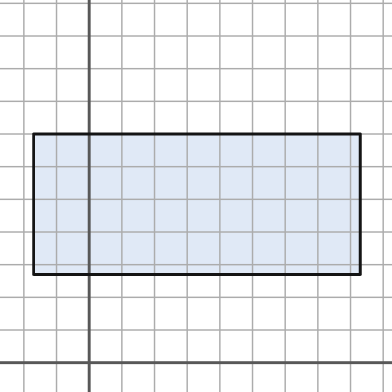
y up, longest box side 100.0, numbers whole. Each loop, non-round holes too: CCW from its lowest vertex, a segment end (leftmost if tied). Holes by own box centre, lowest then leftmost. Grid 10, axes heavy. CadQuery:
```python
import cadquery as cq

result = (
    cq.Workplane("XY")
    .moveTo(-17.0, 27.0)
    .lineTo(83.0, 27.0)
    .lineTo(83.0, 70.0)
    .lineTo(-17.0, 70.0)
    .close()
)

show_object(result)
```